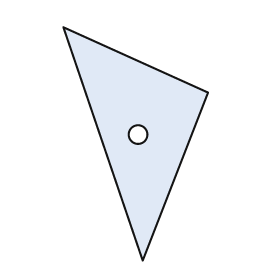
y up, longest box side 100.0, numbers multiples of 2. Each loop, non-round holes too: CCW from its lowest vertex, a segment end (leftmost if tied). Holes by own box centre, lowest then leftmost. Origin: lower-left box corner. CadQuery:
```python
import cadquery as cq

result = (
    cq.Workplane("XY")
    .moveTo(34.0, 0.0)
    .lineTo(62.0, 72.0)
    .lineTo(0.0, 100.0)
    .close()
    .moveTo(32.0, 54.0)
    .circle(4.0)
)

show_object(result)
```